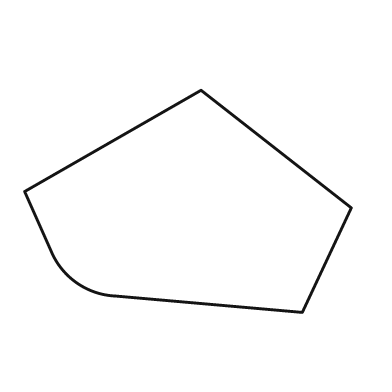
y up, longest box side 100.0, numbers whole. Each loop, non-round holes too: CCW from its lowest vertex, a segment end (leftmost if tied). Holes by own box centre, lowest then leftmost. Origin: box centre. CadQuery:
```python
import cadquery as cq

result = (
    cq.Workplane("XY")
    .moveTo(35.0, -34.0)
    .lineTo(50.0, -2.0)
    .lineTo(4.0, 34.0)
    .lineTo(-50.0, 3.0)
    .lineTo(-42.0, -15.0)
    .threePointArc((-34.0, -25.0), (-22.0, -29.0))
    .close()
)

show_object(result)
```